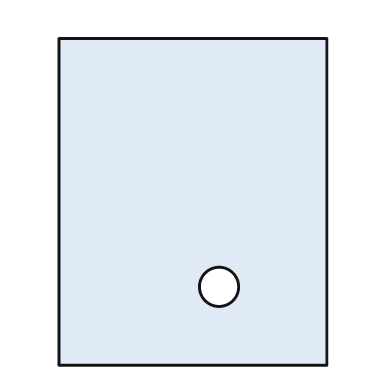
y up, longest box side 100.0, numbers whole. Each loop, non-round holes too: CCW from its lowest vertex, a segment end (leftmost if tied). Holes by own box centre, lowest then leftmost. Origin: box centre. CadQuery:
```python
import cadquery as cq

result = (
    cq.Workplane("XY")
    .moveTo(-41.0, -50.0)
    .lineTo(41.0, -50.0)
    .lineTo(41.0, 50.0)
    .lineTo(-41.0, 50.0)
    .close()
    .moveTo(8.0, -26.0)
    .circle(6.0)
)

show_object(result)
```